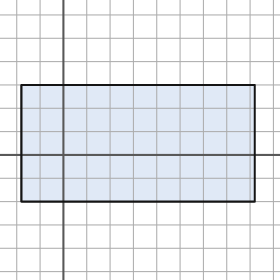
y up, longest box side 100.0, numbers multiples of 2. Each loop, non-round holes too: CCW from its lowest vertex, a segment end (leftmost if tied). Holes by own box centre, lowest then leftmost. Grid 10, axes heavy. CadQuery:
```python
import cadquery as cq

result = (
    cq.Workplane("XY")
    .moveTo(-18.0, -20.0)
    .lineTo(82.0, -20.0)
    .lineTo(82.0, 30.0)
    .lineTo(-18.0, 30.0)
    .close()
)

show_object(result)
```